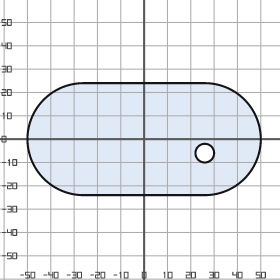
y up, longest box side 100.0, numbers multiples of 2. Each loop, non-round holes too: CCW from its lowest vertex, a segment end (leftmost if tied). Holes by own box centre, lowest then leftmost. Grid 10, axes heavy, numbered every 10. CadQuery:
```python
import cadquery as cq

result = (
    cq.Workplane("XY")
    .moveTo(-26.0, -24.0)
    .lineTo(26.0, -24.0)
    .threePointArc((50.0, 0.0), (26.0, 24.0))
    .lineTo(-26.0, 24.0)
    .threePointArc((-50.0, 0.0), (-26.0, -24.0))
    .close()
    .moveTo(26.0, -6.0)
    .circle(4.0)
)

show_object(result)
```